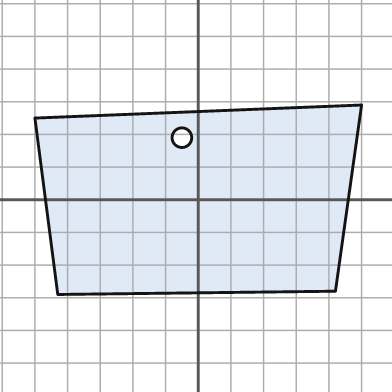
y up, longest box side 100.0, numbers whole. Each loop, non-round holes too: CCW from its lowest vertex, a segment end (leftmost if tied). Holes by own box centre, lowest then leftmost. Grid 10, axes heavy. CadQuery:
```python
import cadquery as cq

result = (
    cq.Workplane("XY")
    .moveTo(-43.0, -29.0)
    .lineTo(42.0, -28.0)
    .lineTo(50.0, 29.0)
    .lineTo(-50.0, 25.0)
    .close()
    .moveTo(-5.0, 19.0)
    .circle(3.0)
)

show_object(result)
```